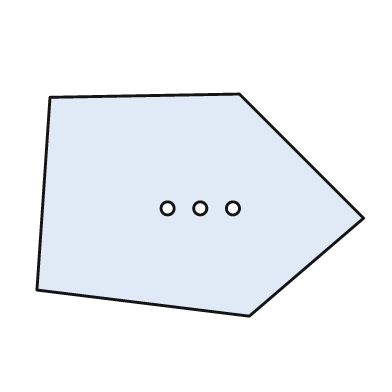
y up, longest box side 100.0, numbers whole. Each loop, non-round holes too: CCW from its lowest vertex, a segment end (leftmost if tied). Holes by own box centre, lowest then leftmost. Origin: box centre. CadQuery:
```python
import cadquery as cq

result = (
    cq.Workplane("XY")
    .moveTo(15.0, -34.0)
    .lineTo(50.0, -4.0)
    .lineTo(12.0, 34.0)
    .lineTo(-46.0, 33.0)
    .lineTo(-50.0, -26.0)
    .close()
    .moveTo(-10.0, -1.0)
    .circle(2.0)
    .moveTo(0.0, -1.0)
    .circle(2.0)
    .moveTo(10.0, -1.0)
    .circle(2.0)
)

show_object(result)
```